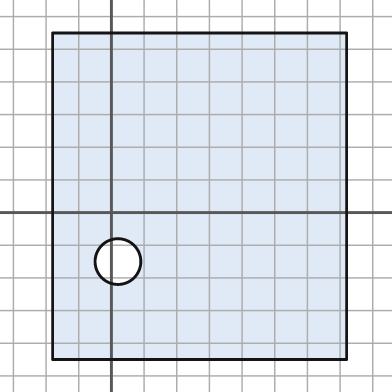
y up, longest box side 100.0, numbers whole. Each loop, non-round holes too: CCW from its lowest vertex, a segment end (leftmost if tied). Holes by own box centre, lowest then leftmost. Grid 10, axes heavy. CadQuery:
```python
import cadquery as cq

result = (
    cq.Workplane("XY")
    .moveTo(-18.0, -45.0)
    .lineTo(72.0, -45.0)
    .lineTo(72.0, 55.0)
    .lineTo(-18.0, 55.0)
    .close()
    .moveTo(2.0, -15.0)
    .circle(7.0)
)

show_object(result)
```